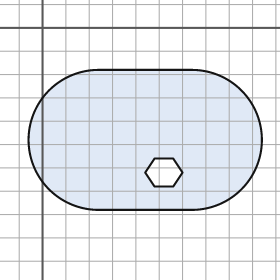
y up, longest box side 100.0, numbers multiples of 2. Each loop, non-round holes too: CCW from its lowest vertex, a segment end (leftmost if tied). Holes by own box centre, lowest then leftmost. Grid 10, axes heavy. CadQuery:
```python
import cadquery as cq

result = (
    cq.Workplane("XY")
    .moveTo(24.0, -78.0)
    .lineTo(64.0, -78.0)
    .threePointArc((94.0, -48.0), (64.0, -18.0))
    .lineTo(24.0, -18.0)
    .threePointArc((-6.0, -48.0), (24.0, -78.0))
    .close()
    .moveTo(48.0, -68.0)
    .lineTo(56.0, -68.0)
    .lineTo(60.0, -62.0)
    .lineTo(56.0, -56.0)
    .lineTo(48.0, -56.0)
    .lineTo(44.0, -62.0)
    .close()
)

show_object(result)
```